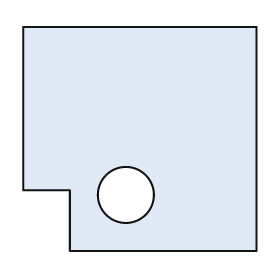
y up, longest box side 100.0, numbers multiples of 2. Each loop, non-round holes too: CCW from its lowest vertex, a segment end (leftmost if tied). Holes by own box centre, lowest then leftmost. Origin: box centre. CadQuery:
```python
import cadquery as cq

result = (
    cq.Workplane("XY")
    .moveTo(-30.0, -48.0)
    .lineTo(50.0, -48.0)
    .lineTo(50.0, 48.0)
    .lineTo(-50.0, 48.0)
    .lineTo(-50.0, -22.0)
    .lineTo(-30.0, -22.0)
    .close()
    .moveTo(-6.0, -24.0)
    .circle(12.0)
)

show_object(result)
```